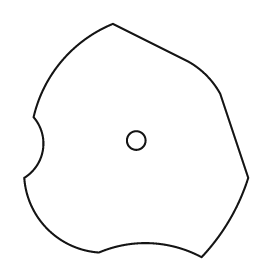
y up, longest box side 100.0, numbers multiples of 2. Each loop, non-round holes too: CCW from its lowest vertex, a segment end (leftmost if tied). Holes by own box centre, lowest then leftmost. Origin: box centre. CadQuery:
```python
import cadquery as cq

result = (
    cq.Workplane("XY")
    .moveTo(28.0, -50.0)
    .threePointArc((40.0, -34.0), (48.0, -16.0))
    .lineTo(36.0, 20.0)
    .threePointArc((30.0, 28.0), (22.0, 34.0))
    .lineTo(-10.0, 50.0)
    .threePointArc((-32.0, 34.0), (-44.0, 10.0))
    .threePointArc((-40.0, -4.0), (-48.0, -16.0))
    .threePointArc((-38.0, -38.0), (-16.0, -48.0))
    .threePointArc((6.0, -44.0), (28.0, -50.0))
    .close()
    .moveTo(0.0, 0.0)
    .circle(4.0)
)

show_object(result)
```